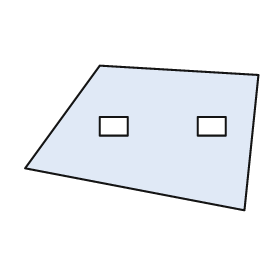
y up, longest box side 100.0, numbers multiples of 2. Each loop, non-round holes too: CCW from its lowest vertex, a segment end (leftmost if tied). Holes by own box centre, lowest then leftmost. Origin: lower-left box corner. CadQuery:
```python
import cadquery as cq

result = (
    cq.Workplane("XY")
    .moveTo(94.0, 0.0)
    .lineTo(100.0, 58.0)
    .lineTo(32.0, 62.0)
    .lineTo(0.0, 18.0)
    .close()
    .moveTo(32.0, 32.0)
    .lineTo(44.0, 32.0)
    .lineTo(44.0, 40.0)
    .lineTo(32.0, 40.0)
    .close()
    .moveTo(74.0, 32.0)
    .lineTo(86.0, 32.0)
    .lineTo(86.0, 40.0)
    .lineTo(74.0, 40.0)
    .close()
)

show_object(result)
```